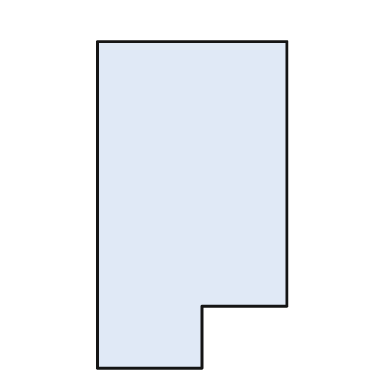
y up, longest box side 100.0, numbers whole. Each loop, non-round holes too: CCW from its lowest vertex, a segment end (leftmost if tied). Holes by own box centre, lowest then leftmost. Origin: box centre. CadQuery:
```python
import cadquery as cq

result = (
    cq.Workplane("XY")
    .moveTo(-29.0, -50.0)
    .lineTo(3.0, -50.0)
    .lineTo(3.0, -31.0)
    .lineTo(29.0, -31.0)
    .lineTo(29.0, 50.0)
    .lineTo(-29.0, 50.0)
    .close()
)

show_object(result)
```